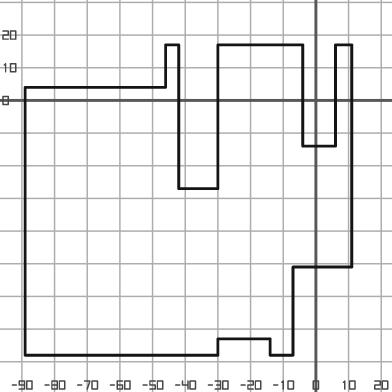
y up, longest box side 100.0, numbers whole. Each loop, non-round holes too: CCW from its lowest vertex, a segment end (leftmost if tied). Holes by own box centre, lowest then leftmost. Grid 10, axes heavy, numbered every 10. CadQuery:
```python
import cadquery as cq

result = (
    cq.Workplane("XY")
    .moveTo(-89.0, -78.0)
    .lineTo(-30.0, -78.0)
    .lineTo(-30.0, -73.0)
    .lineTo(-14.0, -73.0)
    .lineTo(-14.0, -78.0)
    .lineTo(-7.0, -78.0)
    .lineTo(-7.0, -51.0)
    .lineTo(11.0, -51.0)
    .lineTo(11.0, 17.0)
    .lineTo(6.0, 17.0)
    .lineTo(6.0, -14.0)
    .lineTo(-4.0, -14.0)
    .lineTo(-4.0, 17.0)
    .lineTo(-30.0, 17.0)
    .lineTo(-30.0, -27.0)
    .lineTo(-42.0, -27.0)
    .lineTo(-42.0, 17.0)
    .lineTo(-46.0, 17.0)
    .lineTo(-46.0, 4.0)
    .lineTo(-89.0, 4.0)
    .close()
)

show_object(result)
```